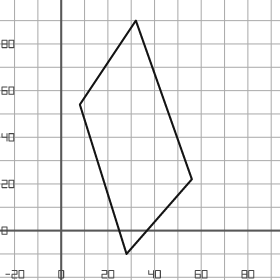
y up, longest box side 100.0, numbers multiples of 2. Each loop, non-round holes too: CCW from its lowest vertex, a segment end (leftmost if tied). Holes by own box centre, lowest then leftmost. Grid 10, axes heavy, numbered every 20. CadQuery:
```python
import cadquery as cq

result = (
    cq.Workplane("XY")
    .moveTo(28.0, -10.0)
    .lineTo(56.0, 22.0)
    .lineTo(32.0, 90.0)
    .lineTo(8.0, 54.0)
    .close()
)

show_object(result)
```